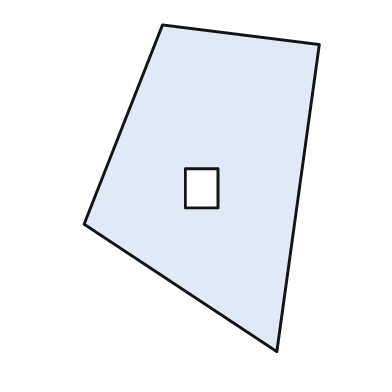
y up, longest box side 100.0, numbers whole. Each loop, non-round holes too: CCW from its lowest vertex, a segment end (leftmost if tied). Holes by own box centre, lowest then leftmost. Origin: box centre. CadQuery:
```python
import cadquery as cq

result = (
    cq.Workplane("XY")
    .moveTo(23.0, -50.0)
    .lineTo(36.0, 44.0)
    .lineTo(-12.0, 50.0)
    .lineTo(-36.0, -11.0)
    .close()
    .moveTo(-5.0, -6.0)
    .lineTo(5.0, -6.0)
    .lineTo(5.0, 6.0)
    .lineTo(-5.0, 6.0)
    .close()
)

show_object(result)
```